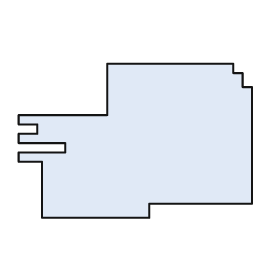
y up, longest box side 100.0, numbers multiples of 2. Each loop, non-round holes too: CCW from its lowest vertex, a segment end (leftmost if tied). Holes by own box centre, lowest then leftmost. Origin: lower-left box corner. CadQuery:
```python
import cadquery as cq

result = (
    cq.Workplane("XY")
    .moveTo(10.0, 0.0)
    .lineTo(56.0, 0.0)
    .lineTo(56.0, 6.0)
    .lineTo(100.0, 6.0)
    .lineTo(100.0, 56.0)
    .lineTo(96.0, 56.0)
    .lineTo(96.0, 62.0)
    .lineTo(92.0, 62.0)
    .lineTo(92.0, 66.0)
    .lineTo(38.0, 66.0)
    .lineTo(38.0, 44.0)
    .lineTo(0.0, 44.0)
    .lineTo(0.0, 40.0)
    .lineTo(8.0, 40.0)
    .lineTo(8.0, 36.0)
    .lineTo(0.0, 36.0)
    .lineTo(0.0, 32.0)
    .lineTo(20.0, 32.0)
    .lineTo(20.0, 28.0)
    .lineTo(0.0, 28.0)
    .lineTo(0.0, 24.0)
    .lineTo(10.0, 24.0)
    .close()
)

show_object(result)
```